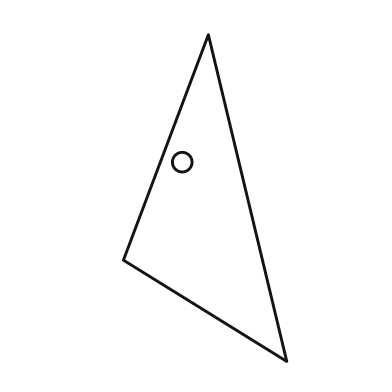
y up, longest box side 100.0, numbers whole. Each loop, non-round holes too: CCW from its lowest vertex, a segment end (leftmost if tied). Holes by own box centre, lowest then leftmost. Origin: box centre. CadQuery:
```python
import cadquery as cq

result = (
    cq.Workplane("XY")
    .moveTo(25.0, -50.0)
    .lineTo(1.0, 50.0)
    .lineTo(-25.0, -19.0)
    .close()
    .moveTo(-7.0, 11.0)
    .circle(3.0)
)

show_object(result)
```